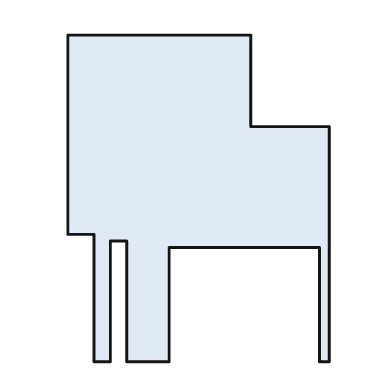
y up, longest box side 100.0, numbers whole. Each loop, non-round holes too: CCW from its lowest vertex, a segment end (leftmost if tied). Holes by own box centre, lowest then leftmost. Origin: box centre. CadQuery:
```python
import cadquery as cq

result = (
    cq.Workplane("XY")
    .moveTo(-32.0, -50.0)
    .lineTo(-27.0, -50.0)
    .lineTo(-27.0, -13.0)
    .lineTo(-22.0, -13.0)
    .lineTo(-22.0, -50.0)
    .lineTo(-9.0, -50.0)
    .lineTo(-9.0, -15.0)
    .lineTo(37.0, -15.0)
    .lineTo(37.0, -50.0)
    .lineTo(40.0, -50.0)
    .lineTo(40.0, 22.0)
    .lineTo(16.0, 22.0)
    .lineTo(16.0, 50.0)
    .lineTo(-40.0, 50.0)
    .lineTo(-40.0, -11.0)
    .lineTo(-32.0, -11.0)
    .close()
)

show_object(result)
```